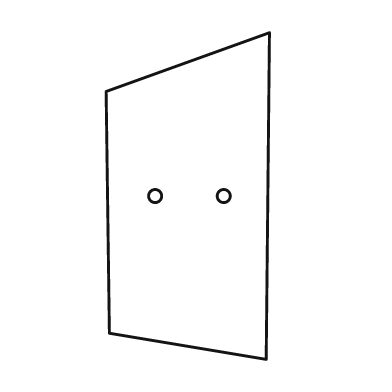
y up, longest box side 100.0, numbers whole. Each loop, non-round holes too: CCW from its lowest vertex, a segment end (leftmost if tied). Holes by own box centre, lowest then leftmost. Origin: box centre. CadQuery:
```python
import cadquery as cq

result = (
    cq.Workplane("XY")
    .moveTo(24.0, -50.0)
    .lineTo(25.0, 50.0)
    .lineTo(-25.0, 32.0)
    .lineTo(-24.0, -42.0)
    .close()
    .moveTo(-10.0, 0.0)
    .circle(2.0)
    .moveTo(11.0, 0.0)
    .circle(2.0)
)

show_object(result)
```